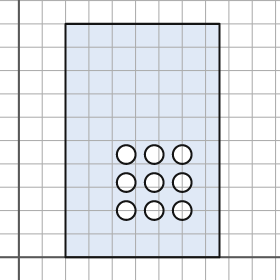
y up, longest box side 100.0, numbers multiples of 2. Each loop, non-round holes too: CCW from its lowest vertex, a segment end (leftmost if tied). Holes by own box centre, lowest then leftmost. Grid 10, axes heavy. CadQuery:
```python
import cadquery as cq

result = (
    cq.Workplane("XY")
    .moveTo(20.0, 0.0)
    .lineTo(86.0, 0.0)
    .lineTo(86.0, 100.0)
    .lineTo(20.0, 100.0)
    .close()
    .moveTo(46.0, 20.0)
    .circle(4.0)
    .moveTo(58.0, 20.0)
    .circle(4.0)
    .moveTo(70.0, 20.0)
    .circle(4.0)
    .moveTo(46.0, 32.0)
    .circle(4.0)
    .moveTo(58.0, 32.0)
    .circle(4.0)
    .moveTo(70.0, 32.0)
    .circle(4.0)
    .moveTo(46.0, 44.0)
    .circle(4.0)
    .moveTo(58.0, 44.0)
    .circle(4.0)
    .moveTo(70.0, 44.0)
    .circle(4.0)
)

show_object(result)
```